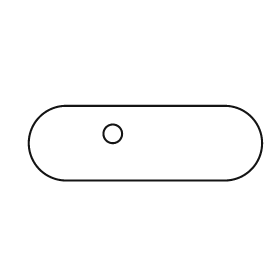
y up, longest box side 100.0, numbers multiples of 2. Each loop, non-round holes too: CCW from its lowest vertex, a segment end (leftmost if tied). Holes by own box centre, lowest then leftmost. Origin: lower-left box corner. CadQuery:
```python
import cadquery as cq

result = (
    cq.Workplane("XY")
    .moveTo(16.0, 0.0)
    .lineTo(84.0, 0.0)
    .threePointArc((100.0, 16.0), (84.0, 32.0))
    .lineTo(16.0, 32.0)
    .threePointArc((0.0, 16.0), (16.0, 0.0))
    .close()
    .moveTo(36.0, 20.0)
    .circle(4.0)
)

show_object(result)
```